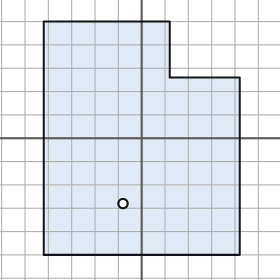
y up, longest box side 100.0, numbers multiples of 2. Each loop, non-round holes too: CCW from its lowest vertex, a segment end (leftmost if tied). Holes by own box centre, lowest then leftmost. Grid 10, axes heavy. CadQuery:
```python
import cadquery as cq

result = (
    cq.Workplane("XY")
    .moveTo(-42.0, -50.0)
    .lineTo(42.0, -50.0)
    .lineTo(42.0, 26.0)
    .lineTo(12.0, 26.0)
    .lineTo(12.0, 50.0)
    .lineTo(-42.0, 50.0)
    .close()
    .moveTo(-8.0, -28.0)
    .circle(2.0)
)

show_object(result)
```